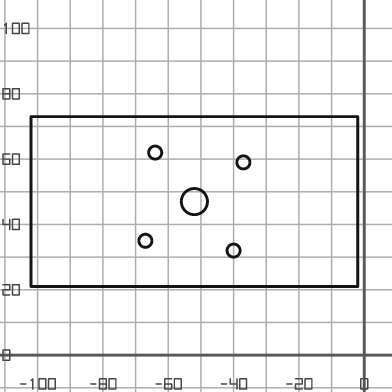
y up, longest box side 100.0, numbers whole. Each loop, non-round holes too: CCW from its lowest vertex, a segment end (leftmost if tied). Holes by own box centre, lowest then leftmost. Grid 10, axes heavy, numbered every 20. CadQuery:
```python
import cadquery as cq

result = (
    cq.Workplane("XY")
    .moveTo(-102.0, 21.0)
    .lineTo(-2.0, 21.0)
    .lineTo(-2.0, 73.0)
    .lineTo(-102.0, 73.0)
    .close()
    .moveTo(-40.0, 32.0)
    .circle(2.0)
    .moveTo(-67.0, 35.0)
    .circle(2.0)
    .moveTo(-52.0, 47.0)
    .circle(4.0)
    .moveTo(-37.0, 59.0)
    .circle(2.0)
    .moveTo(-64.0, 62.0)
    .circle(2.0)
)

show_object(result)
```